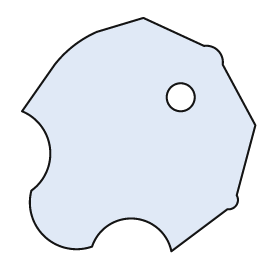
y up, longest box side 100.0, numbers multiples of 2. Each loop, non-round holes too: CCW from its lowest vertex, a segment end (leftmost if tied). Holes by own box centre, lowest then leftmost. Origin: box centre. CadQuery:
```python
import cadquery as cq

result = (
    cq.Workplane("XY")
    .moveTo(14.0, -50.0)
    .lineTo(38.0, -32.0)
    .threePointArc((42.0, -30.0), (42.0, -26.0))
    .lineTo(50.0, 4.0)
    .lineTo(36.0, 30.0)
    .threePointArc((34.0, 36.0), (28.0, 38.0))
    .lineTo(2.0, 50.0)
    .lineTo(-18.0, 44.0)
    .threePointArc((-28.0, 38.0), (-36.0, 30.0))
    .lineTo(-50.0, 10.0)
    .threePointArc((-38.0, -6.0), (-46.0, -24.0))
    .threePointArc((-40.0, -44.0), (-20.0, -48.0))
    .threePointArc((-2.0, -36.0), (14.0, -50.0))
    .close()
    .moveTo(18.0, 16.0)
    .circle(6.0)
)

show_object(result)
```